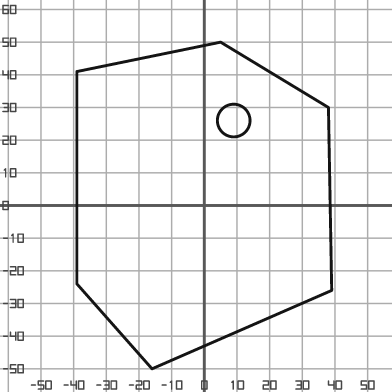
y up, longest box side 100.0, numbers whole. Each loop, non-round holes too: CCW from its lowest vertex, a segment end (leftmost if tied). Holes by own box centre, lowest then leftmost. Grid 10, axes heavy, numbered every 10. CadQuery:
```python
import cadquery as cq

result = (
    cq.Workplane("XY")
    .moveTo(-16.0, -50.0)
    .lineTo(39.0, -26.0)
    .lineTo(38.0, 30.0)
    .lineTo(5.0, 50.0)
    .lineTo(-39.0, 41.0)
    .lineTo(-39.0, -24.0)
    .close()
    .moveTo(9.0, 26.0)
    .circle(5.0)
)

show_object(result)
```